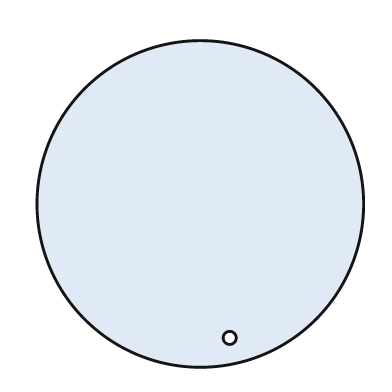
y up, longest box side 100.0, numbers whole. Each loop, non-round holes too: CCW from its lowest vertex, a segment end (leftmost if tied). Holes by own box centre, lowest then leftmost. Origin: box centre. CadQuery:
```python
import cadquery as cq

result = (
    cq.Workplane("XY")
    .moveTo(0.0, 0.0)
    .circle(50.0)
    .moveTo(9.0, -41.0)
    .circle(2.0)
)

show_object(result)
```